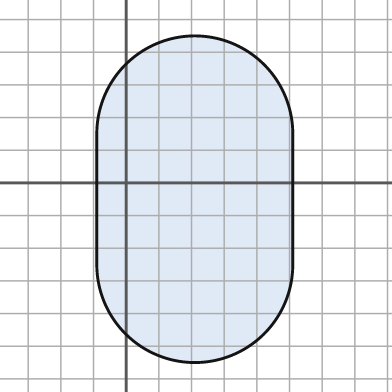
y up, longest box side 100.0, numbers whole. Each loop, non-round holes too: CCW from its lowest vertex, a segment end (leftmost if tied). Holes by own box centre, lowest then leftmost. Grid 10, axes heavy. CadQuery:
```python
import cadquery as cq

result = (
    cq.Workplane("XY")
    .moveTo(-9.0, -25.0)
    .threePointArc((21.0, -55.0), (51.0, -25.0))
    .lineTo(51.0, 15.0)
    .threePointArc((21.0, 45.0), (-9.0, 15.0))
    .close()
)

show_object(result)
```